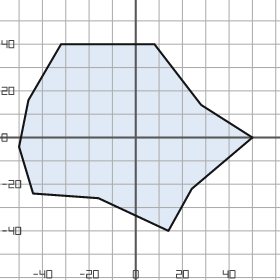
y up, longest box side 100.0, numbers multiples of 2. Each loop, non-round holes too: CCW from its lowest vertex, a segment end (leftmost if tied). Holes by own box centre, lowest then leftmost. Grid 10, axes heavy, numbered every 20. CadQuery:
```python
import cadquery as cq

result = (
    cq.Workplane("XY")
    .moveTo(14.0, -40.0)
    .lineTo(24.0, -22.0)
    .lineTo(50.0, 0.0)
    .lineTo(28.0, 14.0)
    .lineTo(8.0, 40.0)
    .lineTo(-32.0, 40.0)
    .lineTo(-46.0, 16.0)
    .lineTo(-50.0, -4.0)
    .lineTo(-44.0, -24.0)
    .lineTo(-16.0, -26.0)
    .close()
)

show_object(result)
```